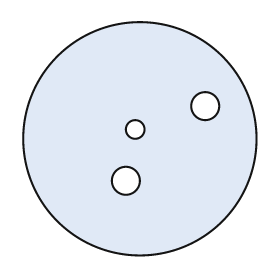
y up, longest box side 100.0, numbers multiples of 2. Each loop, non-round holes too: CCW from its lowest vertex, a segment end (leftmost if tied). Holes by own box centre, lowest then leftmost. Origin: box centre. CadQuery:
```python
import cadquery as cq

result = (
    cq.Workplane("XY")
    .moveTo(0.0, 0.0)
    .circle(50.0)
    .moveTo(-6.0, -18.0)
    .circle(6.0)
    .moveTo(-2.0, 4.0)
    .circle(4.0)
    .moveTo(28.0, 14.0)
    .circle(6.0)
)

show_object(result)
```